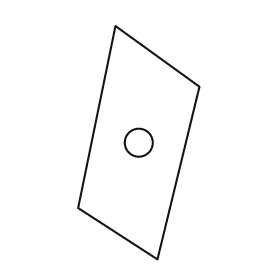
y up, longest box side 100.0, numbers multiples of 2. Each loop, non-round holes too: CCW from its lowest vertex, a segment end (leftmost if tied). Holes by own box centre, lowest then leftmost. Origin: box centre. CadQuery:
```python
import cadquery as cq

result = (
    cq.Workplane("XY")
    .moveTo(8.0, -50.0)
    .lineTo(26.0, 24.0)
    .lineTo(-10.0, 50.0)
    .lineTo(-26.0, -28.0)
    .close()
    .moveTo(0.0, 0.0)
    .circle(6.0)
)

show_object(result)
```